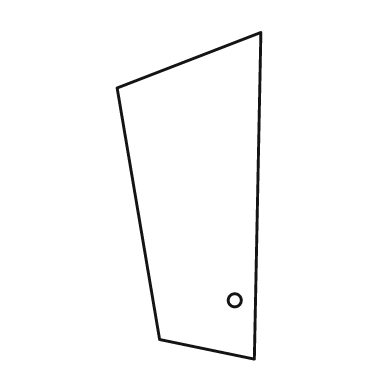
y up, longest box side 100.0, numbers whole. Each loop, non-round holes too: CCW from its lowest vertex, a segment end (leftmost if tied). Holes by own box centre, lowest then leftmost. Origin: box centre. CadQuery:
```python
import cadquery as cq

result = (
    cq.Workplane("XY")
    .moveTo(20.0, -50.0)
    .lineTo(22.0, 50.0)
    .lineTo(-22.0, 33.0)
    .lineTo(-9.0, -44.0)
    .close()
    .moveTo(14.0, -32.0)
    .circle(2.0)
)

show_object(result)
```